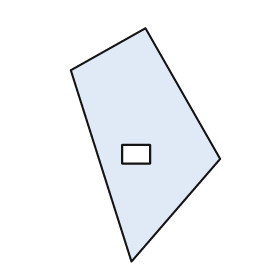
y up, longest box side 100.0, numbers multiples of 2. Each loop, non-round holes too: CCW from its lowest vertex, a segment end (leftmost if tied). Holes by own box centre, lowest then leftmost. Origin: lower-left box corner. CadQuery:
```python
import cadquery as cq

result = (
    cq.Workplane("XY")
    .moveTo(26.0, 0.0)
    .lineTo(64.0, 44.0)
    .lineTo(32.0, 100.0)
    .lineTo(0.0, 82.0)
    .close()
    .moveTo(22.0, 42.0)
    .lineTo(34.0, 42.0)
    .lineTo(34.0, 50.0)
    .lineTo(22.0, 50.0)
    .close()
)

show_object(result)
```